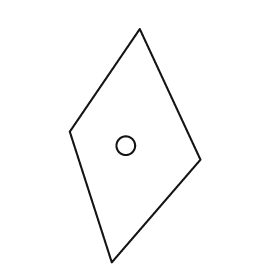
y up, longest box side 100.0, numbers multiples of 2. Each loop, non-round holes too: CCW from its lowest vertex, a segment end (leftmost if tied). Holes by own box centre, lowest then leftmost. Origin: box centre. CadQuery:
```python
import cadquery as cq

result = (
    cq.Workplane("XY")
    .moveTo(-10.0, -50.0)
    .lineTo(28.0, -6.0)
    .lineTo(2.0, 50.0)
    .lineTo(-28.0, 6.0)
    .close()
    .moveTo(-4.0, 0.0)
    .circle(4.0)
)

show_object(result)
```